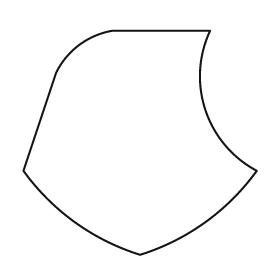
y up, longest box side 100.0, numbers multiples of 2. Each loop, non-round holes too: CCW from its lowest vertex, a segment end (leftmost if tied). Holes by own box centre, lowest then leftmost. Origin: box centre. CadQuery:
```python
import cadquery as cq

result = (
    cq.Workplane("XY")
    .moveTo(0.0, -48.0)
    .threePointArc((28.0, -34.0), (50.0, -12.0))
    .threePointArc((28.0, 14.0), (30.0, 48.0))
    .lineTo(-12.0, 48.0)
    .threePointArc((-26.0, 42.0), (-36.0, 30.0))
    .lineTo(-50.0, -12.0)
    .threePointArc((-28.0, -34.0), (0.0, -48.0))
    .close()
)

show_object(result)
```